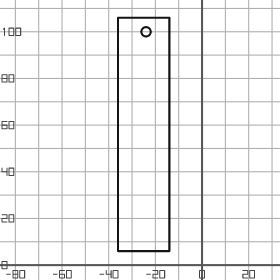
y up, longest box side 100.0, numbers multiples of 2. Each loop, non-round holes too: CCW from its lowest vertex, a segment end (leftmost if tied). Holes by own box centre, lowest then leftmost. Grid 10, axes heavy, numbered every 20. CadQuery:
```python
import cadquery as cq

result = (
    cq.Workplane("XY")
    .moveTo(-36.0, 6.0)
    .lineTo(-14.0, 6.0)
    .lineTo(-14.0, 106.0)
    .lineTo(-36.0, 106.0)
    .close()
    .moveTo(-24.0, 100.0)
    .circle(2.0)
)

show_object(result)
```